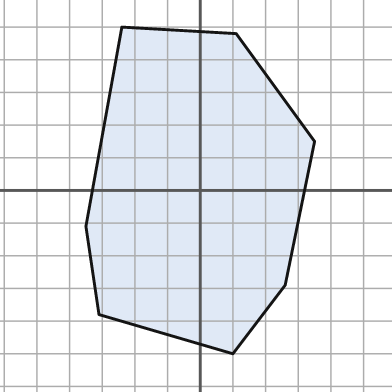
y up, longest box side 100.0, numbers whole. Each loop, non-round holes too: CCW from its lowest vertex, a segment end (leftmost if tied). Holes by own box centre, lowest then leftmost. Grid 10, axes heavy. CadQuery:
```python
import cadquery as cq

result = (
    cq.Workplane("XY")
    .moveTo(10.0, -50.0)
    .lineTo(26.0, -29.0)
    .lineTo(35.0, 15.0)
    .lineTo(11.0, 48.0)
    .lineTo(-24.0, 50.0)
    .lineTo(-35.0, -11.0)
    .lineTo(-31.0, -38.0)
    .close()
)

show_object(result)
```